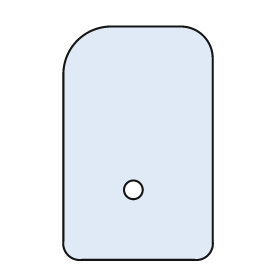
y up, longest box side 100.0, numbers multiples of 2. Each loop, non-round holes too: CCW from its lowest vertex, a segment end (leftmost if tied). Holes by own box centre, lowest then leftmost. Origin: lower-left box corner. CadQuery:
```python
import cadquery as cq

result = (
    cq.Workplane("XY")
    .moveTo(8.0, 0.0)
    .lineTo(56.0, 0.0)
    .threePointArc((62.0, 2.0), (64.0, 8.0))
    .lineTo(64.0, 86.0)
    .threePointArc((60.0, 96.0), (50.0, 100.0))
    .lineTo(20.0, 100.0)
    .threePointArc((6.0, 94.0), (0.0, 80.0))
    .lineTo(0.0, 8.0)
    .threePointArc((2.0, 2.0), (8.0, 0.0))
    .close()
    .moveTo(30.0, 30.0)
    .circle(4.0)
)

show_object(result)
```